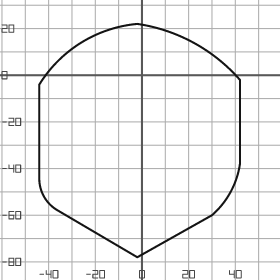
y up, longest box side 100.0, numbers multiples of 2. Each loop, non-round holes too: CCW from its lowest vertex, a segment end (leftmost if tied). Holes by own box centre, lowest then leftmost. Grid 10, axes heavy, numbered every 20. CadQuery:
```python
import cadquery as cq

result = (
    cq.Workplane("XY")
    .moveTo(-2.0, -78.0)
    .lineTo(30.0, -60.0)
    .threePointArc((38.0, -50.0), (42.0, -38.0))
    .lineTo(42.0, -2.0)
    .threePointArc((22.0, 14.0), (-2.0, 22.0))
    .threePointArc((-26.0, 14.0), (-44.0, -4.0))
    .lineTo(-44.0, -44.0)
    .threePointArc((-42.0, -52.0), (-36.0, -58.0))
    .close()
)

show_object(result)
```